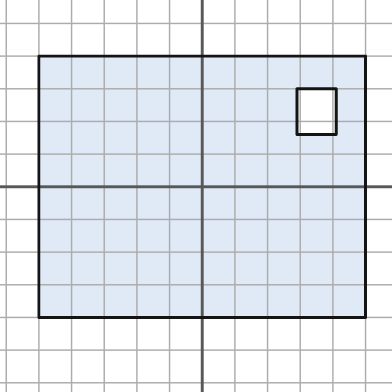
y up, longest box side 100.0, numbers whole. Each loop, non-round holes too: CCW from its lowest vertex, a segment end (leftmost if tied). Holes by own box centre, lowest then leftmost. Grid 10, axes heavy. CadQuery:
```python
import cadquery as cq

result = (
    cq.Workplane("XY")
    .moveTo(-50.0, -40.0)
    .lineTo(50.0, -40.0)
    .lineTo(50.0, 40.0)
    .lineTo(-50.0, 40.0)
    .close()
    .moveTo(29.0, 16.0)
    .lineTo(41.0, 16.0)
    .lineTo(41.0, 30.0)
    .lineTo(29.0, 30.0)
    .close()
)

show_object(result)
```